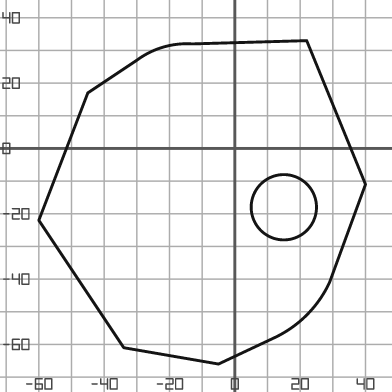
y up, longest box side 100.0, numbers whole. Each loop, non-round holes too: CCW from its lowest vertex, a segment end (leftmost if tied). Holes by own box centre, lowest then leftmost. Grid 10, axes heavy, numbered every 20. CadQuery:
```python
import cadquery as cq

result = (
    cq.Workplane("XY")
    .moveTo(-5.0, -66.0)
    .lineTo(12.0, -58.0)
    .threePointArc((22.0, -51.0), (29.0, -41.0))
    .lineTo(40.0, -11.0)
    .lineTo(22.0, 33.0)
    .lineTo(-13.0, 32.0)
    .threePointArc((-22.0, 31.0), (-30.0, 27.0))
    .lineTo(-45.0, 17.0)
    .lineTo(-60.0, -22.0)
    .lineTo(-34.0, -61.0)
    .close()
    .moveTo(15.0, -18.0)
    .circle(10.0)
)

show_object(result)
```